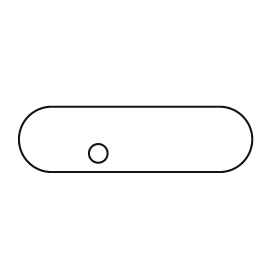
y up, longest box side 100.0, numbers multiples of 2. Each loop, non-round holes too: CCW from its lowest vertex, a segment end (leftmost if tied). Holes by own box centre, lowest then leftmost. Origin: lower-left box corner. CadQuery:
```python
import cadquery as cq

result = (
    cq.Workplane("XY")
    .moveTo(14.0, 0.0)
    .lineTo(86.0, 0.0)
    .threePointArc((100.0, 14.0), (86.0, 28.0))
    .lineTo(14.0, 28.0)
    .threePointArc((0.0, 14.0), (14.0, 0.0))
    .close()
    .moveTo(34.0, 8.0)
    .circle(4.0)
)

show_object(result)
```